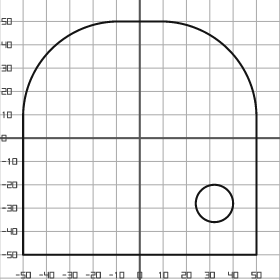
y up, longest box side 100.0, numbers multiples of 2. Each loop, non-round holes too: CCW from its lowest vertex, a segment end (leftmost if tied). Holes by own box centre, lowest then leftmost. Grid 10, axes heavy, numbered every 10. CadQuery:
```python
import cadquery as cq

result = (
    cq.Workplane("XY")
    .moveTo(-50.0, -50.0)
    .lineTo(50.0, -50.0)
    .lineTo(50.0, 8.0)
    .threePointArc((38.0, 38.0), (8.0, 50.0))
    .lineTo(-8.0, 50.0)
    .threePointArc((-38.0, 38.0), (-50.0, 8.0))
    .close()
    .moveTo(32.0, -28.0)
    .circle(8.0)
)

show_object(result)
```